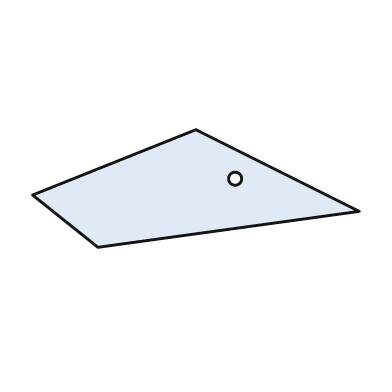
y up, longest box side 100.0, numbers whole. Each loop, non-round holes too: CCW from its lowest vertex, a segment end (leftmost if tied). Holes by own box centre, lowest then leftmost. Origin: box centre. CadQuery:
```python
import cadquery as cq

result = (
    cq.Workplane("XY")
    .moveTo(-30.0, -18.0)
    .lineTo(50.0, -7.0)
    .lineTo(0.0, 18.0)
    .lineTo(-50.0, -2.0)
    .close()
    .moveTo(12.0, 3.0)
    .circle(2.0)
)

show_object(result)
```